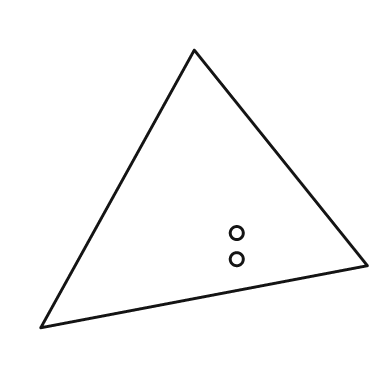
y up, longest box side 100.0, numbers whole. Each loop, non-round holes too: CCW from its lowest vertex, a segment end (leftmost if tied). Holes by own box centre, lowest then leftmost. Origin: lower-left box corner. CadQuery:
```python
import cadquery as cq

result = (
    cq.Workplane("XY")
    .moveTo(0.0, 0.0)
    .lineTo(100.0, 19.0)
    .lineTo(47.0, 85.0)
    .close()
    .moveTo(60.0, 21.0)
    .circle(2.0)
    .moveTo(60.0, 29.0)
    .circle(2.0)
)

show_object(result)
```